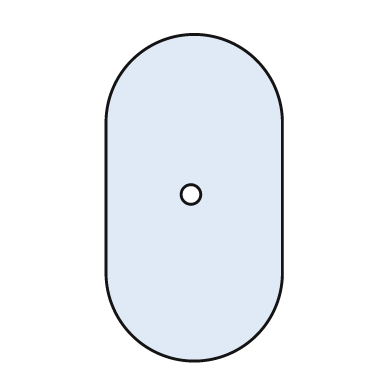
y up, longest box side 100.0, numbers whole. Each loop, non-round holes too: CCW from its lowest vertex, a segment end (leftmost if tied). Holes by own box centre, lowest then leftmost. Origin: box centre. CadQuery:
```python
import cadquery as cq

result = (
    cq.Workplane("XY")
    .moveTo(-27.0, -23.0)
    .threePointArc((0.0, -50.0), (27.0, -23.0))
    .lineTo(27.0, 23.0)
    .threePointArc((0.0, 50.0), (-27.0, 23.0))
    .close()
    .moveTo(-1.0, 1.0)
    .circle(3.0)
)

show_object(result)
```